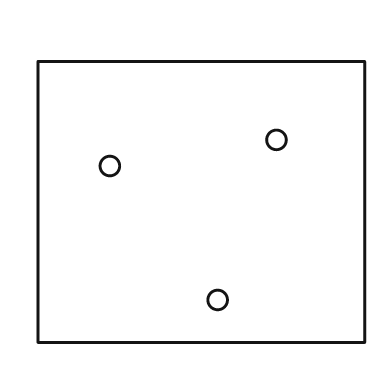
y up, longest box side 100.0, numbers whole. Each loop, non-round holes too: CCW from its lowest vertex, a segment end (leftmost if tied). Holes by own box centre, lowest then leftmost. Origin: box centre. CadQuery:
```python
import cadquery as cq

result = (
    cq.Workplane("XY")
    .moveTo(-50.0, -43.0)
    .lineTo(50.0, -43.0)
    .lineTo(50.0, 43.0)
    .lineTo(-50.0, 43.0)
    .close()
    .moveTo(5.0, -30.0)
    .circle(3.0)
    .moveTo(-28.0, 11.0)
    .circle(3.0)
    .moveTo(23.0, 19.0)
    .circle(3.0)
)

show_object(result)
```